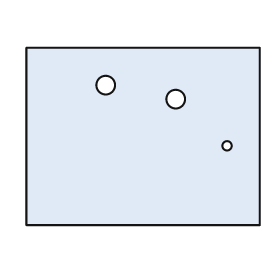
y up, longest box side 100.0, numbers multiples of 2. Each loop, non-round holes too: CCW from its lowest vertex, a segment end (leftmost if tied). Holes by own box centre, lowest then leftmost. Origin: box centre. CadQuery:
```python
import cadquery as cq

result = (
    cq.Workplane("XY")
    .moveTo(-50.0, -38.0)
    .lineTo(50.0, -38.0)
    .lineTo(50.0, 38.0)
    .lineTo(-50.0, 38.0)
    .close()
    .moveTo(36.0, -4.0)
    .circle(2.0)
    .moveTo(14.0, 16.0)
    .circle(4.0)
    .moveTo(-16.0, 22.0)
    .circle(4.0)
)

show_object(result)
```